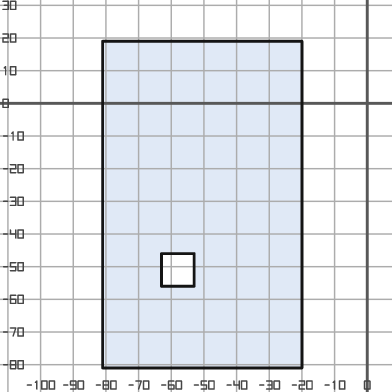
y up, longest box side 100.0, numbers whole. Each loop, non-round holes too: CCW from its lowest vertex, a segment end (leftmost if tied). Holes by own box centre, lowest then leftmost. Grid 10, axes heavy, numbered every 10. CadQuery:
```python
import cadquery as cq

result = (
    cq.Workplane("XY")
    .moveTo(-81.0, -81.0)
    .lineTo(-20.0, -81.0)
    .lineTo(-20.0, 19.0)
    .lineTo(-81.0, 19.0)
    .close()
    .moveTo(-63.0, -56.0)
    .lineTo(-53.0, -56.0)
    .lineTo(-53.0, -46.0)
    .lineTo(-63.0, -46.0)
    .close()
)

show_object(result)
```